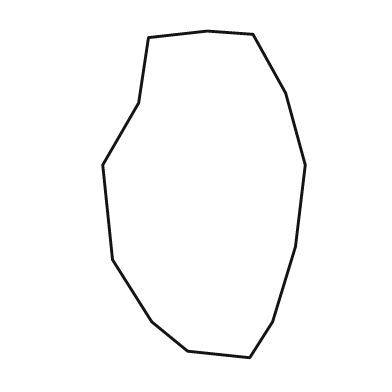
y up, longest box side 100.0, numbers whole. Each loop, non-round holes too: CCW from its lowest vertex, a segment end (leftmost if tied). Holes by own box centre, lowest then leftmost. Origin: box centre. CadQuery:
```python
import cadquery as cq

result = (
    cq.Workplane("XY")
    .moveTo(14.0, -50.0)
    .lineTo(21.0, -39.0)
    .lineTo(28.0, -16.0)
    .lineTo(31.0, 9.0)
    .lineTo(25.0, 31.0)
    .lineTo(15.0, 49.0)
    .lineTo(1.0, 50.0)
    .lineTo(-17.0, 48.0)
    .lineTo(-20.0, 28.0)
    .lineTo(-31.0, 9.0)
    .lineTo(-28.0, -20.0)
    .lineTo(-16.0, -39.0)
    .lineTo(-5.0, -48.0)
    .close()
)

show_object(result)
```